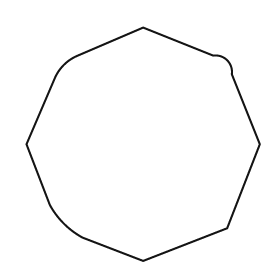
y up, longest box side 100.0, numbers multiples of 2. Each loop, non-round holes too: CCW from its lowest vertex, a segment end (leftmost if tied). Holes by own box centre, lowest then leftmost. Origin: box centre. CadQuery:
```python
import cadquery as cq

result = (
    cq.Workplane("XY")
    .moveTo(0.0, -50.0)
    .lineTo(36.0, -36.0)
    .lineTo(50.0, 0.0)
    .lineTo(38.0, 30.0)
    .threePointArc((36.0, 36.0), (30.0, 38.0))
    .lineTo(0.0, 50.0)
    .lineTo(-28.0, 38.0)
    .threePointArc((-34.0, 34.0), (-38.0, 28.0))
    .lineTo(-50.0, 0.0)
    .lineTo(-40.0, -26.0)
    .threePointArc((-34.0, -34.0), (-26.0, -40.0))
    .close()
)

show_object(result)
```